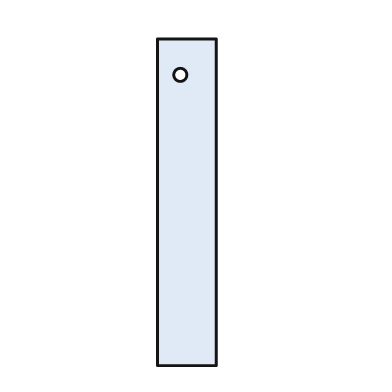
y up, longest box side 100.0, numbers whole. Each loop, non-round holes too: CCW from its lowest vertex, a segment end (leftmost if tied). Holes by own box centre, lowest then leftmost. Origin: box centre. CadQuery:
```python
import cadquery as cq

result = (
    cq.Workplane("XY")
    .moveTo(-9.0, -50.0)
    .lineTo(9.0, -50.0)
    .lineTo(9.0, 50.0)
    .lineTo(-9.0, 50.0)
    .close()
    .moveTo(-2.0, 39.0)
    .circle(2.0)
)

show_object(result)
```